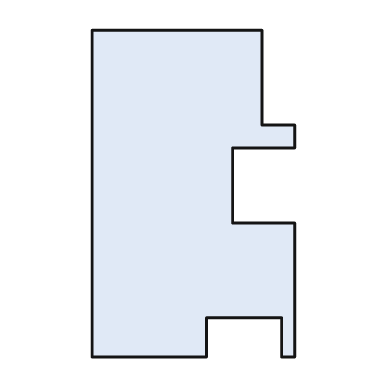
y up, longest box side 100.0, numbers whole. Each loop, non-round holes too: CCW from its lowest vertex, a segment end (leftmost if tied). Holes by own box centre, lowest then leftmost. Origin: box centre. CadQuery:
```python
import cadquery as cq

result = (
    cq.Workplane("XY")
    .moveTo(-31.0, -50.0)
    .lineTo(4.0, -50.0)
    .lineTo(4.0, -38.0)
    .lineTo(27.0, -38.0)
    .lineTo(27.0, -50.0)
    .lineTo(31.0, -50.0)
    .lineTo(31.0, -9.0)
    .lineTo(12.0, -9.0)
    .lineTo(12.0, 14.0)
    .lineTo(31.0, 14.0)
    .lineTo(31.0, 21.0)
    .lineTo(21.0, 21.0)
    .lineTo(21.0, 50.0)
    .lineTo(-31.0, 50.0)
    .close()
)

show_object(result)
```